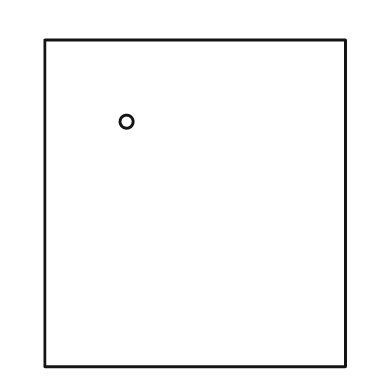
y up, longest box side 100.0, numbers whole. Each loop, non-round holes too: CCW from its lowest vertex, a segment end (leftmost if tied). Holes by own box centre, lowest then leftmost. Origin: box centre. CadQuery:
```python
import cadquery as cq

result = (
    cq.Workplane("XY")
    .moveTo(-46.0, -50.0)
    .lineTo(46.0, -50.0)
    .lineTo(46.0, 50.0)
    .lineTo(-46.0, 50.0)
    .close()
    .moveTo(-21.0, 25.0)
    .circle(2.0)
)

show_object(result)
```